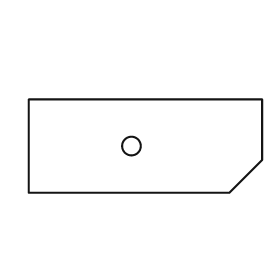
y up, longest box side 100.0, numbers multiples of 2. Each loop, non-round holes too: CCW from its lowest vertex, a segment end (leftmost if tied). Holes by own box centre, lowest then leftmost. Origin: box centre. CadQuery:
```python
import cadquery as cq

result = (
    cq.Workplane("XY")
    .moveTo(-50.0, -20.0)
    .lineTo(36.0, -20.0)
    .lineTo(50.0, -6.0)
    .lineTo(50.0, 20.0)
    .lineTo(-50.0, 20.0)
    .close()
    .moveTo(-6.0, 0.0)
    .circle(4.0)
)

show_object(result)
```